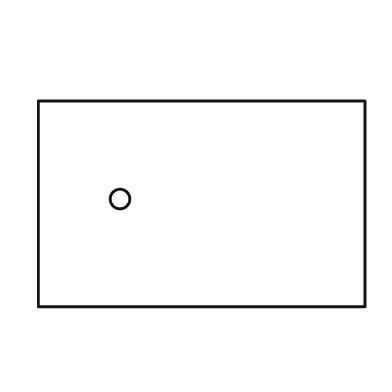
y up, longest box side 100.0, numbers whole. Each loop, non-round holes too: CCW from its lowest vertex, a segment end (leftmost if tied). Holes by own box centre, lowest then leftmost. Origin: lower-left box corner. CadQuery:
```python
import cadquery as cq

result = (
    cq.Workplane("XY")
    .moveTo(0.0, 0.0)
    .lineTo(100.0, 0.0)
    .lineTo(100.0, 63.0)
    .lineTo(0.0, 63.0)
    .close()
    .moveTo(25.0, 33.0)
    .circle(3.0)
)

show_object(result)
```